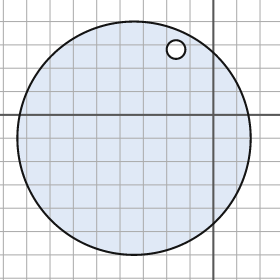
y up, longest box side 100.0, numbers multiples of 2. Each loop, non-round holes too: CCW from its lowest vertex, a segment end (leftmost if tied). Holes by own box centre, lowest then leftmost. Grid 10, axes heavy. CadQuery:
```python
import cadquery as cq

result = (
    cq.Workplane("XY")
    .moveTo(-34.0, -10.0)
    .circle(50.0)
    .moveTo(-16.0, 28.0)
    .circle(4.0)
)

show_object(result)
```